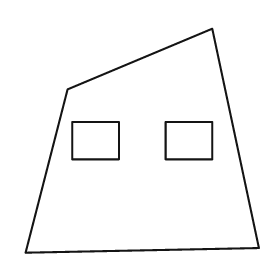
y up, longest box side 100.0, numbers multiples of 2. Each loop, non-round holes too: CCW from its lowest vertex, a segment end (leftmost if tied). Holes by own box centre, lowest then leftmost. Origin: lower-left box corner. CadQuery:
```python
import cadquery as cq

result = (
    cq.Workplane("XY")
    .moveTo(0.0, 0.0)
    .lineTo(100.0, 2.0)
    .lineTo(80.0, 96.0)
    .lineTo(18.0, 70.0)
    .close()
    .moveTo(20.0, 40.0)
    .lineTo(40.0, 40.0)
    .lineTo(40.0, 56.0)
    .lineTo(20.0, 56.0)
    .close()
    .moveTo(60.0, 40.0)
    .lineTo(80.0, 40.0)
    .lineTo(80.0, 56.0)
    .lineTo(60.0, 56.0)
    .close()
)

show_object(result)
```